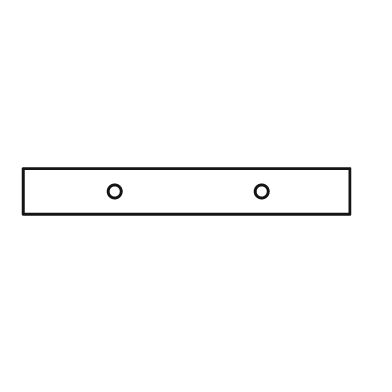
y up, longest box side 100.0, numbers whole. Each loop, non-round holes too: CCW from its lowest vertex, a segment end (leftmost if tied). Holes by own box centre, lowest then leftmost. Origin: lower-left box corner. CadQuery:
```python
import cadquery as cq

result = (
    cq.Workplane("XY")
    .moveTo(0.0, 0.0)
    .lineTo(100.0, 0.0)
    .lineTo(100.0, 14.0)
    .lineTo(0.0, 14.0)
    .close()
    .moveTo(28.0, 7.0)
    .circle(2.0)
    .moveTo(73.0, 7.0)
    .circle(2.0)
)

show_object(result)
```